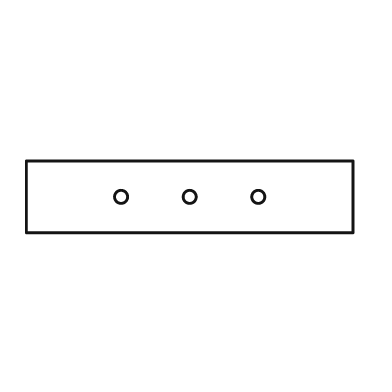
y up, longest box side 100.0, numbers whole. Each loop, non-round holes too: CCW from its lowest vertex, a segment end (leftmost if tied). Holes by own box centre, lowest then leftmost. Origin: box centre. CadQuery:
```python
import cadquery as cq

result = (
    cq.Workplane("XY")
    .moveTo(-50.0, -11.0)
    .lineTo(50.0, -11.0)
    .lineTo(50.0, 11.0)
    .lineTo(-50.0, 11.0)
    .close()
    .moveTo(-21.0, 0.0)
    .circle(2.0)
    .moveTo(0.0, 0.0)
    .circle(2.0)
    .moveTo(21.0, 0.0)
    .circle(2.0)
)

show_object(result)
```